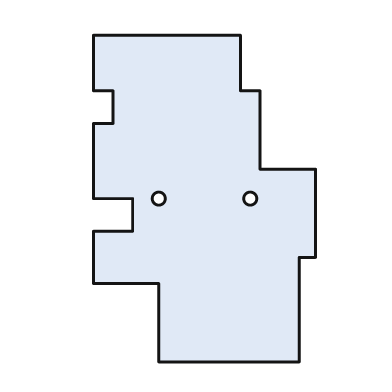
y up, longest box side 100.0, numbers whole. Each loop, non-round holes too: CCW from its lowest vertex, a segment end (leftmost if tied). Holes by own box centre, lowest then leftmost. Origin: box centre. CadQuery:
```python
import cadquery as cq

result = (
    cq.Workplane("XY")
    .moveTo(-14.0, -50.0)
    .lineTo(29.0, -50.0)
    .lineTo(29.0, -18.0)
    .lineTo(34.0, -18.0)
    .lineTo(34.0, 9.0)
    .lineTo(17.0, 9.0)
    .lineTo(17.0, 33.0)
    .lineTo(11.0, 33.0)
    .lineTo(11.0, 50.0)
    .lineTo(-34.0, 50.0)
    .lineTo(-34.0, 33.0)
    .lineTo(-28.0, 33.0)
    .lineTo(-28.0, 23.0)
    .lineTo(-34.0, 23.0)
    .lineTo(-34.0, 0.0)
    .lineTo(-22.0, 0.0)
    .lineTo(-22.0, -10.0)
    .lineTo(-34.0, -10.0)
    .lineTo(-34.0, -26.0)
    .lineTo(-14.0, -26.0)
    .close()
    .moveTo(-14.0, 0.0)
    .circle(2.0)
    .moveTo(14.0, 0.0)
    .circle(2.0)
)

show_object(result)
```